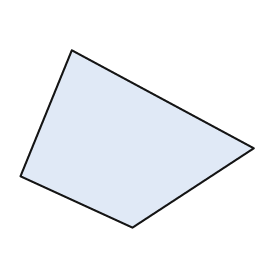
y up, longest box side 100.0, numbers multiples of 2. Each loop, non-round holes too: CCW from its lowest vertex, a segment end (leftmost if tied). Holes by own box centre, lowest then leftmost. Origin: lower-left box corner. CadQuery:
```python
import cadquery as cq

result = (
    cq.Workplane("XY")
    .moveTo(48.0, 0.0)
    .lineTo(100.0, 34.0)
    .lineTo(22.0, 76.0)
    .lineTo(0.0, 22.0)
    .close()
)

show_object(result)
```